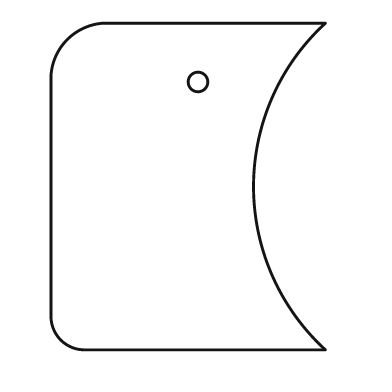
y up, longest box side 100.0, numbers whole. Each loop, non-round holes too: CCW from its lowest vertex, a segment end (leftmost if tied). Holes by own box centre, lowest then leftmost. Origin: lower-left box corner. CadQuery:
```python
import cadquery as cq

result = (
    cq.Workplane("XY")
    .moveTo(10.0, 0.0)
    .lineTo(84.0, 0.0)
    .threePointArc((62.0, 50.0), (84.0, 100.0))
    .lineTo(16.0, 100.0)
    .threePointArc((5.0, 95.0), (0.0, 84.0))
    .lineTo(0.0, 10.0)
    .threePointArc((3.0, 3.0), (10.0, 0.0))
    .close()
    .moveTo(45.0, 82.0)
    .circle(3.0)
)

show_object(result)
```